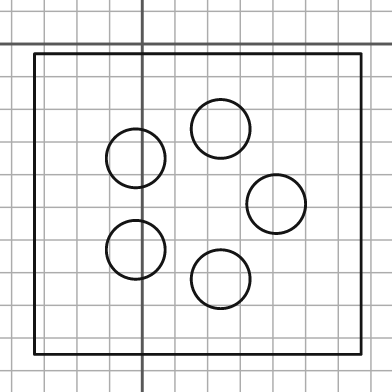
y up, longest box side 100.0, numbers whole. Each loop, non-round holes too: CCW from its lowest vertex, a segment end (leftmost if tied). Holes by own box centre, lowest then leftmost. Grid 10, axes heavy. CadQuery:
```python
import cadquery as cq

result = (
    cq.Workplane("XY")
    .moveTo(-33.0, -95.0)
    .lineTo(67.0, -95.0)
    .lineTo(67.0, -3.0)
    .lineTo(-33.0, -3.0)
    .close()
    .moveTo(24.0, -72.0)
    .circle(9.0)
    .moveTo(-2.0, -63.0)
    .circle(9.0)
    .moveTo(41.0, -49.0)
    .circle(9.0)
    .moveTo(-2.0, -35.0)
    .circle(9.0)
    .moveTo(24.0, -26.0)
    .circle(9.0)
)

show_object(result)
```